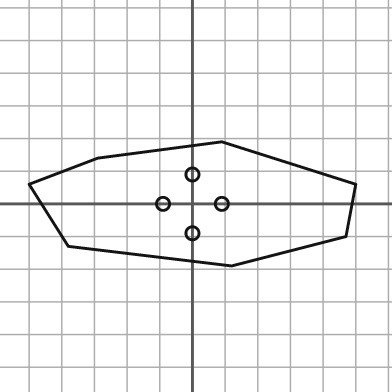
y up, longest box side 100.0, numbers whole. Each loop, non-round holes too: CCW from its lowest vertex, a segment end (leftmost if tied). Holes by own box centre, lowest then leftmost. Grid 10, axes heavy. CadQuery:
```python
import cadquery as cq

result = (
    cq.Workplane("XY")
    .moveTo(12.0, -19.0)
    .lineTo(47.0, -10.0)
    .lineTo(50.0, 6.0)
    .lineTo(9.0, 19.0)
    .lineTo(-29.0, 14.0)
    .lineTo(-50.0, 6.0)
    .lineTo(-38.0, -13.0)
    .close()
    .moveTo(0.0, -9.0)
    .circle(2.0)
    .moveTo(-9.0, 0.0)
    .circle(2.0)
    .moveTo(9.0, 0.0)
    .circle(2.0)
    .moveTo(0.0, 9.0)
    .circle(2.0)
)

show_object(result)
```